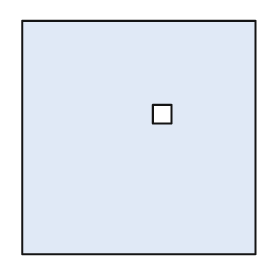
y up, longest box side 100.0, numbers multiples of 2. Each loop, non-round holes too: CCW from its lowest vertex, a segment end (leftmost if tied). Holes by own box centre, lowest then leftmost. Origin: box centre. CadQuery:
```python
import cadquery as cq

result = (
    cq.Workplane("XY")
    .moveTo(-50.0, -50.0)
    .lineTo(50.0, -50.0)
    .lineTo(50.0, 50.0)
    .lineTo(-50.0, 50.0)
    .close()
    .moveTo(6.0, 6.0)
    .lineTo(14.0, 6.0)
    .lineTo(14.0, 14.0)
    .lineTo(6.0, 14.0)
    .close()
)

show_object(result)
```